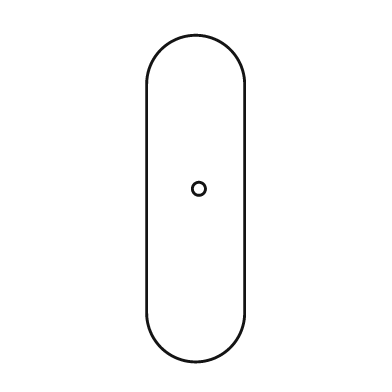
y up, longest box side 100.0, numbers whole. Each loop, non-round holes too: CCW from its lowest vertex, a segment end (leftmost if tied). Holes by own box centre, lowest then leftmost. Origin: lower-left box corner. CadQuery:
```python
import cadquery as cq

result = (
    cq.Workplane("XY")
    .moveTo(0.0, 15.0)
    .threePointArc((15.0, 0.0), (30.0, 15.0))
    .lineTo(30.0, 85.0)
    .threePointArc((15.0, 100.0), (0.0, 85.0))
    .close()
    .moveTo(16.0, 53.0)
    .circle(2.0)
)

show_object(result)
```